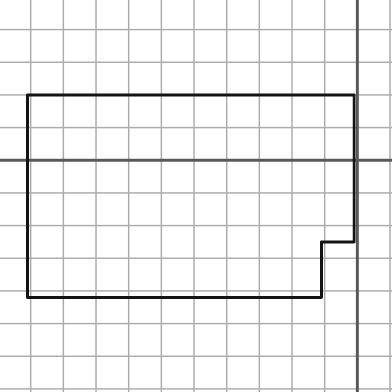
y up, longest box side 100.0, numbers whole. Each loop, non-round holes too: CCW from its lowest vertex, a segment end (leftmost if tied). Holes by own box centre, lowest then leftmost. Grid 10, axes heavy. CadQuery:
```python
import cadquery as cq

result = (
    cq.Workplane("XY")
    .moveTo(-101.0, -42.0)
    .lineTo(-11.0, -42.0)
    .lineTo(-11.0, -25.0)
    .lineTo(-1.0, -25.0)
    .lineTo(-1.0, 20.0)
    .lineTo(-101.0, 20.0)
    .close()
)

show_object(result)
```